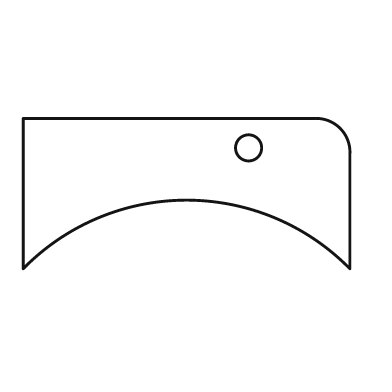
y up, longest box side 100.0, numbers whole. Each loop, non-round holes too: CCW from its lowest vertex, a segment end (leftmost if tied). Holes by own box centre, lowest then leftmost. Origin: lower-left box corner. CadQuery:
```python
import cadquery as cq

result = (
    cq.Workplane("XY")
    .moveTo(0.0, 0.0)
    .threePointArc((50.0, 21.0), (100.0, 0.0))
    .lineTo(100.0, 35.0)
    .threePointArc((97.0, 43.0), (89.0, 46.0))
    .lineTo(0.0, 46.0)
    .close()
    .moveTo(69.0, 37.0)
    .circle(4.0)
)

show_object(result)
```